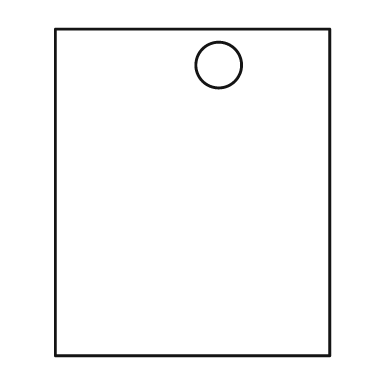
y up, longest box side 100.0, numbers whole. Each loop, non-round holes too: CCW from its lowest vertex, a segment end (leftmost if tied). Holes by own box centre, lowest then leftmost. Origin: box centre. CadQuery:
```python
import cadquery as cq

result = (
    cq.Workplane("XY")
    .moveTo(-42.0, -50.0)
    .lineTo(42.0, -50.0)
    .lineTo(42.0, 50.0)
    .lineTo(-42.0, 50.0)
    .close()
    .moveTo(8.0, 39.0)
    .circle(7.0)
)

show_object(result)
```